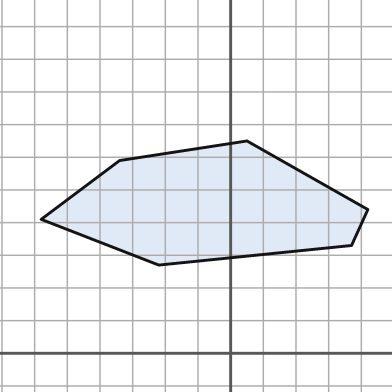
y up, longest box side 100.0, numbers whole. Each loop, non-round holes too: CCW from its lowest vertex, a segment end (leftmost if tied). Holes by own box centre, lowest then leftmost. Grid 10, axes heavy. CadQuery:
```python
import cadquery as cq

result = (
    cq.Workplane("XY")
    .moveTo(-22.0, 27.0)
    .lineTo(37.0, 33.0)
    .lineTo(42.0, 44.0)
    .lineTo(5.0, 65.0)
    .lineTo(-34.0, 59.0)
    .lineTo(-58.0, 41.0)
    .close()
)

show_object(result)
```